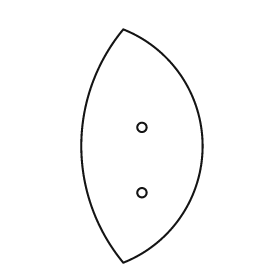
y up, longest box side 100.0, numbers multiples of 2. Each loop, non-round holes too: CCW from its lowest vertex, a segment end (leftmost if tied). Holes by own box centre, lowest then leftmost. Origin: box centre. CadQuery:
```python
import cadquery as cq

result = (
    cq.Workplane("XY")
    .moveTo(-8.0, -50.0)
    .threePointArc((26.0, 0.0), (-8.0, 50.0))
    .threePointArc((-26.0, 0.0), (-8.0, -50.0))
    .close()
    .moveTo(0.0, -20.0)
    .circle(2.0)
    .moveTo(0.0, 8.0)
    .circle(2.0)
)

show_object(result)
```